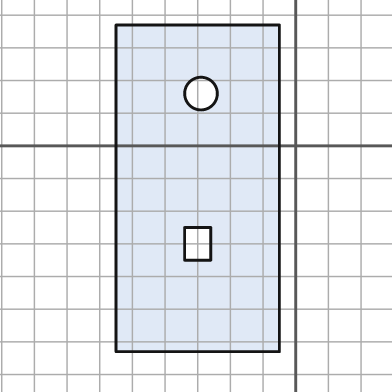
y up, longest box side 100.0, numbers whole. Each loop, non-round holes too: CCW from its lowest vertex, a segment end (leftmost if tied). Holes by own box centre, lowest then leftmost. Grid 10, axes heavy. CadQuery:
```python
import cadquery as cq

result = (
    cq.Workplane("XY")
    .moveTo(-55.0, -63.0)
    .lineTo(-5.0, -63.0)
    .lineTo(-5.0, 37.0)
    .lineTo(-55.0, 37.0)
    .close()
    .moveTo(-34.0, -35.0)
    .lineTo(-26.0, -35.0)
    .lineTo(-26.0, -25.0)
    .lineTo(-34.0, -25.0)
    .close()
    .moveTo(-29.0, 16.0)
    .circle(5.0)
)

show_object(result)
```